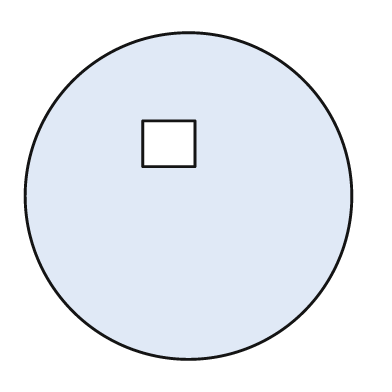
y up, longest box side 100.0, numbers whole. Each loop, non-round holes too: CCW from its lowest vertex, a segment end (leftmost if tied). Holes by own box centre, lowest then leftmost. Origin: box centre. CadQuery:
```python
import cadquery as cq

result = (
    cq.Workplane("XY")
    .moveTo(0.0, 0.0)
    .circle(50.0)
    .moveTo(-14.0, 9.0)
    .lineTo(2.0, 9.0)
    .lineTo(2.0, 23.0)
    .lineTo(-14.0, 23.0)
    .close()
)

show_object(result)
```